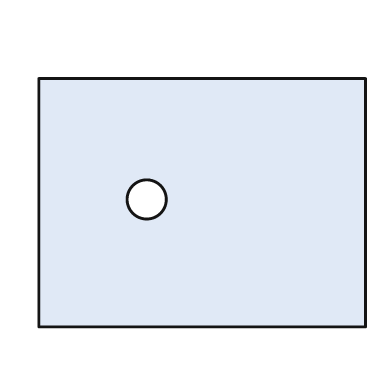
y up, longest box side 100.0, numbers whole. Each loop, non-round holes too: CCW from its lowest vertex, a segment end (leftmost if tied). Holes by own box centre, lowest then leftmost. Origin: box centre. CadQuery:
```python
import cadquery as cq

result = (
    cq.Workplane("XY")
    .moveTo(-50.0, -38.0)
    .lineTo(50.0, -38.0)
    .lineTo(50.0, 38.0)
    .lineTo(-50.0, 38.0)
    .close()
    .moveTo(-17.0, 1.0)
    .circle(6.0)
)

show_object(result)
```